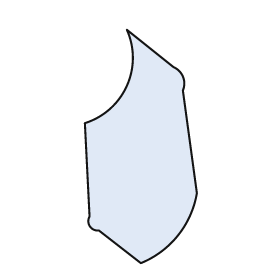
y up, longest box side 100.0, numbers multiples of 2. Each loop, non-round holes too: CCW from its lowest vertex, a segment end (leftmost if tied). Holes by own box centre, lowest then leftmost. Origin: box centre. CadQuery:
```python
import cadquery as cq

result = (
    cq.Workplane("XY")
    .moveTo(0.0, -50.0)
    .threePointArc((16.0, -38.0), (24.0, -20.0))
    .lineTo(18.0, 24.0)
    .threePointArc((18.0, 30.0), (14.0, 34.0))
    .lineTo(-6.0, 50.0)
    .threePointArc((-6.0, 26.0), (-24.0, 10.0))
    .lineTo(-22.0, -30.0)
    .threePointArc((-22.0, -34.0), (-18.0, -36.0))
    .close()
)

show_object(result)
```